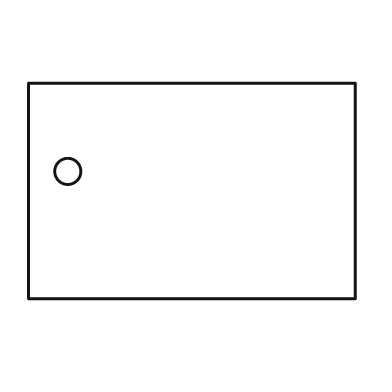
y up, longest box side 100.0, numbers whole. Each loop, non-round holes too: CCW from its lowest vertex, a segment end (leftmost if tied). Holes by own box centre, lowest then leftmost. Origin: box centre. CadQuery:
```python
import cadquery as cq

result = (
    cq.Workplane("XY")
    .moveTo(-50.0, -33.0)
    .lineTo(50.0, -33.0)
    .lineTo(50.0, 33.0)
    .lineTo(-50.0, 33.0)
    .close()
    .moveTo(-38.0, 6.0)
    .circle(4.0)
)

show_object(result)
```